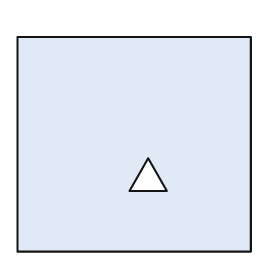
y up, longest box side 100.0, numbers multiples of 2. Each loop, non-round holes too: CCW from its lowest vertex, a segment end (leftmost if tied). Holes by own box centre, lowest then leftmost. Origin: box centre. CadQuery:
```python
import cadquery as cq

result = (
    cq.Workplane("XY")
    .moveTo(-50.0, -46.0)
    .lineTo(50.0, -46.0)
    .lineTo(50.0, 46.0)
    .lineTo(-50.0, 46.0)
    .close()
    .moveTo(-2.0, -20.0)
    .lineTo(14.0, -20.0)
    .lineTo(6.0, -6.0)
    .close()
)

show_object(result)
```